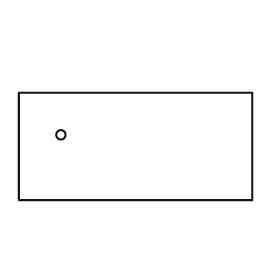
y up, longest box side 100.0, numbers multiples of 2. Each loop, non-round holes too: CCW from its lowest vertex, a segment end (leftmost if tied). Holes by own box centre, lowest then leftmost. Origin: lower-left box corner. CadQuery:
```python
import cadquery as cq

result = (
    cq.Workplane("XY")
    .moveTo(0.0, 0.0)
    .lineTo(100.0, 0.0)
    .lineTo(100.0, 46.0)
    .lineTo(0.0, 46.0)
    .close()
    .moveTo(18.0, 28.0)
    .circle(2.0)
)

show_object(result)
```